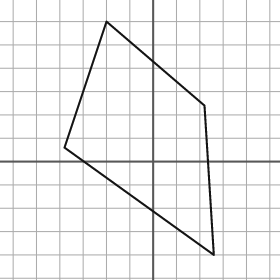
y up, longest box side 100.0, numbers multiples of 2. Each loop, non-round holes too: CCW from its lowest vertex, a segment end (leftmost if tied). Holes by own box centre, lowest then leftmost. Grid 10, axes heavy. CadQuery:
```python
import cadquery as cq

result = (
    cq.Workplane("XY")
    .moveTo(26.0, -40.0)
    .lineTo(22.0, 24.0)
    .lineTo(-20.0, 60.0)
    .lineTo(-38.0, 6.0)
    .close()
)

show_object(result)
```